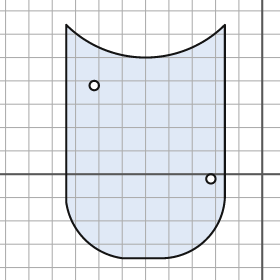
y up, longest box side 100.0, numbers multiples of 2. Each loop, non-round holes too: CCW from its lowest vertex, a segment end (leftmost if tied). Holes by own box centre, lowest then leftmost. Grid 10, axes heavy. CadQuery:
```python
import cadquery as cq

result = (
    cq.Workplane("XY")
    .moveTo(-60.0, -36.0)
    .lineTo(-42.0, -36.0)
    .threePointArc((-24.0, -28.0), (-16.0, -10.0))
    .lineTo(-16.0, 64.0)
    .threePointArc((-50.0, 50.0), (-84.0, 64.0))
    .lineTo(-84.0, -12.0)
    .threePointArc((-76.0, -28.0), (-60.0, -36.0))
    .close()
    .moveTo(-22.0, -2.0)
    .circle(2.0)
    .moveTo(-72.0, 38.0)
    .circle(2.0)
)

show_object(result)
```